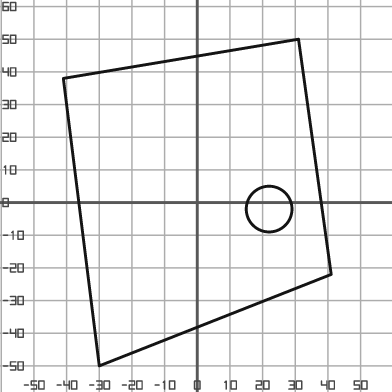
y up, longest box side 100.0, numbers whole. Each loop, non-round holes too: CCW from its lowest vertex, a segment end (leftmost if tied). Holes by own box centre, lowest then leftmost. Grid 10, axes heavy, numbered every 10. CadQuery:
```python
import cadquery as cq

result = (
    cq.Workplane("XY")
    .moveTo(-30.0, -50.0)
    .lineTo(41.0, -22.0)
    .lineTo(31.0, 50.0)
    .lineTo(-41.0, 38.0)
    .close()
    .moveTo(22.0, -2.0)
    .circle(7.0)
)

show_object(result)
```